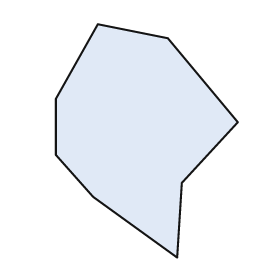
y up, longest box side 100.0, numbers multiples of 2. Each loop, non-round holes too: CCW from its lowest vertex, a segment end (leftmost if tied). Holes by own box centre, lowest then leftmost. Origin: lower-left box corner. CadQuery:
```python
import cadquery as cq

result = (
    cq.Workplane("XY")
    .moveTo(52.0, 0.0)
    .lineTo(54.0, 32.0)
    .lineTo(78.0, 58.0)
    .lineTo(48.0, 94.0)
    .lineTo(18.0, 100.0)
    .lineTo(0.0, 68.0)
    .lineTo(0.0, 44.0)
    .lineTo(16.0, 26.0)
    .close()
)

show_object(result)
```